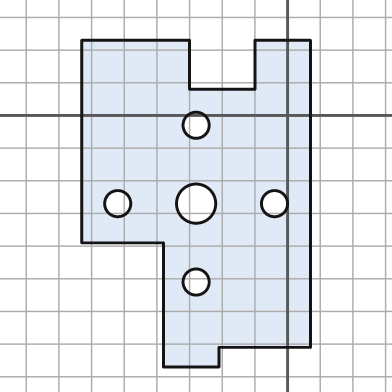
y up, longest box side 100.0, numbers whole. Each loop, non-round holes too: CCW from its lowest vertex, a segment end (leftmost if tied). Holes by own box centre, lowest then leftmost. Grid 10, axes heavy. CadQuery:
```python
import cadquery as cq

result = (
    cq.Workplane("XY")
    .moveTo(-38.0, -77.0)
    .lineTo(-21.0, -77.0)
    .lineTo(-21.0, -71.0)
    .lineTo(7.0, -71.0)
    .lineTo(7.0, 23.0)
    .lineTo(-10.0, 23.0)
    .lineTo(-10.0, 8.0)
    .lineTo(-30.0, 8.0)
    .lineTo(-30.0, 23.0)
    .lineTo(-63.0, 23.0)
    .lineTo(-63.0, -39.0)
    .lineTo(-38.0, -39.0)
    .close()
    .moveTo(-28.0, -51.0)
    .circle(4.0)
    .moveTo(-52.0, -27.0)
    .circle(4.0)
    .moveTo(-28.0, -27.0)
    .circle(6.0)
    .moveTo(-4.0, -27.0)
    .circle(4.0)
    .moveTo(-28.0, -3.0)
    .circle(4.0)
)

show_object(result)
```